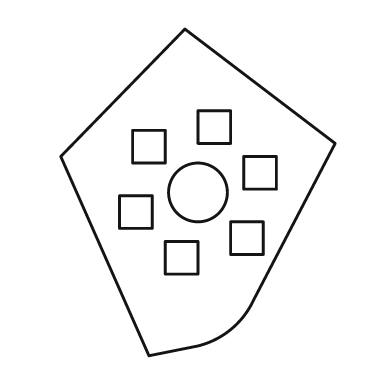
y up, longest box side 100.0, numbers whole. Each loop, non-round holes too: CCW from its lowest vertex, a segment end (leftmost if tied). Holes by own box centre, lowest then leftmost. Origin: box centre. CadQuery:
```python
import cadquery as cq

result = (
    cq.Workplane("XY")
    .moveTo(-15.0, -50.0)
    .lineTo(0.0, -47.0)
    .threePointArc((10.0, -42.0), (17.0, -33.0))
    .lineTo(42.0, 15.0)
    .lineTo(-4.0, 50.0)
    .lineTo(-42.0, 11.0)
    .close()
    .moveTo(-10.0, -25.0)
    .lineTo(0.0, -25.0)
    .lineTo(0.0, -15.0)
    .lineTo(-10.0, -15.0)
    .close()
    .moveTo(10.0, -19.0)
    .lineTo(20.0, -19.0)
    .lineTo(20.0, -9.0)
    .lineTo(10.0, -9.0)
    .close()
    .moveTo(-24.0, -11.0)
    .lineTo(-14.0, -11.0)
    .lineTo(-14.0, -1.0)
    .lineTo(-24.0, -1.0)
    .close()
    .moveTo(0.0, 0.0)
    .circle(9.0)
    .moveTo(14.0, 1.0)
    .lineTo(24.0, 1.0)
    .lineTo(24.0, 11.0)
    .lineTo(14.0, 11.0)
    .close()
    .moveTo(-20.0, 9.0)
    .lineTo(-10.0, 9.0)
    .lineTo(-10.0, 19.0)
    .lineTo(-20.0, 19.0)
    .close()
    .moveTo(0.0, 15.0)
    .lineTo(10.0, 15.0)
    .lineTo(10.0, 25.0)
    .lineTo(0.0, 25.0)
    .close()
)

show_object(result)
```